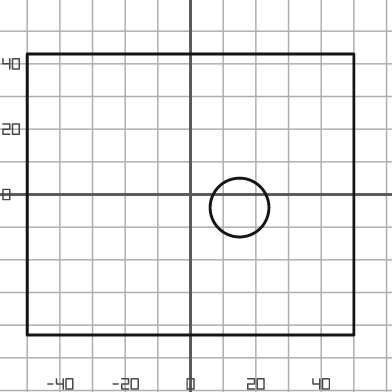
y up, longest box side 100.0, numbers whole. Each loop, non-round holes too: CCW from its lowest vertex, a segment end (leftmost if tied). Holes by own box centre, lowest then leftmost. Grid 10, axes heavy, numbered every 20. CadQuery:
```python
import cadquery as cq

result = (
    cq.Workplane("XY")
    .moveTo(-50.0, -43.0)
    .lineTo(50.0, -43.0)
    .lineTo(50.0, 43.0)
    .lineTo(-50.0, 43.0)
    .close()
    .moveTo(15.0, -4.0)
    .circle(9.0)
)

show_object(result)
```